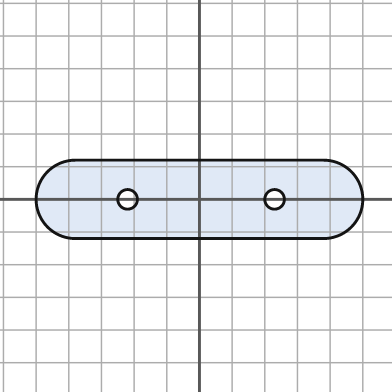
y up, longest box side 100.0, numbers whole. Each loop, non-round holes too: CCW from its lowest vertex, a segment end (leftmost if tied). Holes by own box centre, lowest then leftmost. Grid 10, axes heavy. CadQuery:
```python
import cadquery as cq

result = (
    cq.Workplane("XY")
    .moveTo(-38.0, -12.0)
    .lineTo(38.0, -12.0)
    .threePointArc((50.0, 0.0), (38.0, 12.0))
    .lineTo(-38.0, 12.0)
    .threePointArc((-50.0, 0.0), (-38.0, -12.0))
    .close()
    .moveTo(-22.0, 0.0)
    .circle(3.0)
    .moveTo(23.0, 0.0)
    .circle(3.0)
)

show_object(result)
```